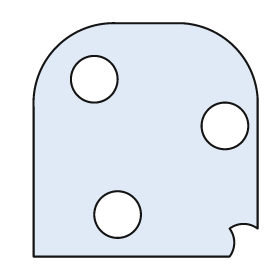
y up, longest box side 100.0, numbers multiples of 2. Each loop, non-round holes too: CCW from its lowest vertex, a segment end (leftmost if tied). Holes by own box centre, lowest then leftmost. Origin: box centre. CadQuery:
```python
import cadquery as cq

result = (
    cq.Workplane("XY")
    .moveTo(-48.0, -50.0)
    .lineTo(36.0, -50.0)
    .threePointArc((38.0, -44.0), (36.0, -38.0))
    .threePointArc((42.0, -36.0), (48.0, -38.0))
    .lineTo(48.0, 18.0)
    .threePointArc((38.0, 40.0), (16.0, 50.0))
    .lineTo(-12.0, 50.0)
    .threePointArc((-38.0, 40.0), (-48.0, 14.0))
    .close()
    .moveTo(-12.0, -32.0)
    .circle(10.0)
    .moveTo(34.0, 6.0)
    .circle(10.0)
    .moveTo(-22.0, 26.0)
    .circle(10.0)
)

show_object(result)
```